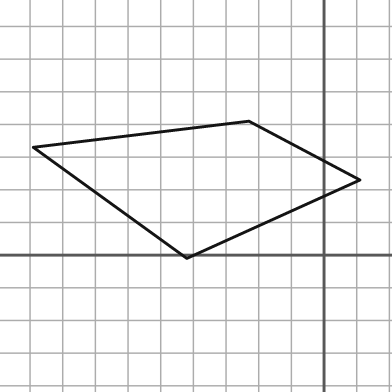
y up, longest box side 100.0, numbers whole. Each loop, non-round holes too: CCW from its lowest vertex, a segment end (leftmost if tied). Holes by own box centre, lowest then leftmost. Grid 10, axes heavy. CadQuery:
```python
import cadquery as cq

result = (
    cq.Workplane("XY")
    .moveTo(-42.0, -1.0)
    .lineTo(11.0, 23.0)
    .lineTo(-23.0, 41.0)
    .lineTo(-89.0, 33.0)
    .close()
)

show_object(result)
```